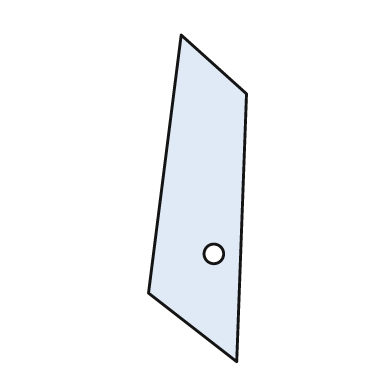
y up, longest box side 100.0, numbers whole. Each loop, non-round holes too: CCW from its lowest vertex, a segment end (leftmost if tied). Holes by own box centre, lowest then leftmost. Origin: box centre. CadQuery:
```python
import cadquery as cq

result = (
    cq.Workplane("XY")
    .moveTo(12.0, -50.0)
    .lineTo(15.0, 32.0)
    .lineTo(-5.0, 50.0)
    .lineTo(-15.0, -29.0)
    .close()
    .moveTo(5.0, -17.0)
    .circle(3.0)
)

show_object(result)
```